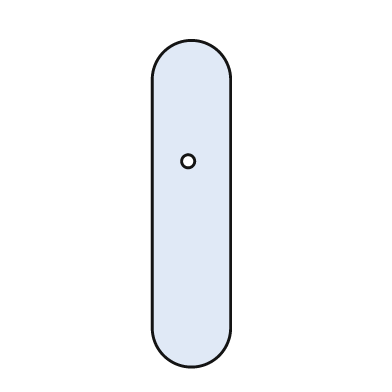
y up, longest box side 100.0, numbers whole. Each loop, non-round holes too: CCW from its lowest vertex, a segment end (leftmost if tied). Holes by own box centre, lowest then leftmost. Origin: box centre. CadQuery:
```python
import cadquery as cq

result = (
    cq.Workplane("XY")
    .moveTo(-12.0, -38.0)
    .threePointArc((0.0, -50.0), (12.0, -38.0))
    .lineTo(12.0, 38.0)
    .threePointArc((0.0, 50.0), (-12.0, 38.0))
    .close()
    .moveTo(-1.0, 13.0)
    .circle(2.0)
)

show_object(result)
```